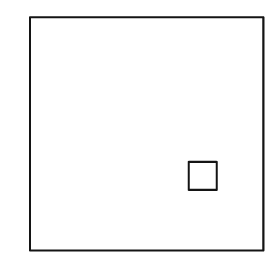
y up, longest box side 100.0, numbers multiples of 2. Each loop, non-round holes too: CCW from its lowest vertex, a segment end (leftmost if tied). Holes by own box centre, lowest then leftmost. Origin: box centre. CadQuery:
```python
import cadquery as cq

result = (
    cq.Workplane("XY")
    .moveTo(-50.0, -50.0)
    .lineTo(50.0, -50.0)
    .lineTo(50.0, 50.0)
    .lineTo(-50.0, 50.0)
    .close()
    .moveTo(18.0, -24.0)
    .lineTo(30.0, -24.0)
    .lineTo(30.0, -12.0)
    .lineTo(18.0, -12.0)
    .close()
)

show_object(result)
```